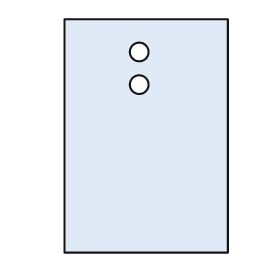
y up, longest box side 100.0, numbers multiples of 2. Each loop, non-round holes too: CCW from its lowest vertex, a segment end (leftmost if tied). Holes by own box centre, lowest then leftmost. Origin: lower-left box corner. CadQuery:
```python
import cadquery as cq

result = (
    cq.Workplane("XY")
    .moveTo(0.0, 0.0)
    .lineTo(70.0, 0.0)
    .lineTo(70.0, 100.0)
    .lineTo(0.0, 100.0)
    .close()
    .moveTo(32.0, 72.0)
    .circle(4.0)
    .moveTo(32.0, 86.0)
    .circle(4.0)
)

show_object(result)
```